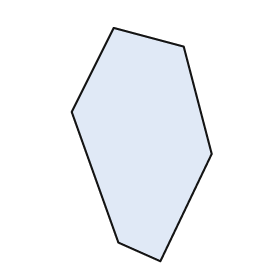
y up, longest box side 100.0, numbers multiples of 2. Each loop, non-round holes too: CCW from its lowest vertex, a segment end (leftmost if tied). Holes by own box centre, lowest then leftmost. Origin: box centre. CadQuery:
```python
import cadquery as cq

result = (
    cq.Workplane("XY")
    .moveTo(8.0, -50.0)
    .lineTo(30.0, -4.0)
    .lineTo(18.0, 42.0)
    .lineTo(-12.0, 50.0)
    .lineTo(-30.0, 14.0)
    .lineTo(-10.0, -42.0)
    .close()
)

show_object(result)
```